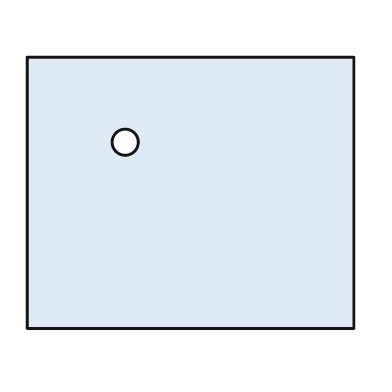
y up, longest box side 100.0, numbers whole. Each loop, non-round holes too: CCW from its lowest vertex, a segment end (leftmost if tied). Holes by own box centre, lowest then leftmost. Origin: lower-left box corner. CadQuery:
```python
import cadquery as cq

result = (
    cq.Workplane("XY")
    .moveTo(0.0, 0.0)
    .lineTo(100.0, 0.0)
    .lineTo(100.0, 83.0)
    .lineTo(0.0, 83.0)
    .close()
    .moveTo(30.0, 57.0)
    .circle(4.0)
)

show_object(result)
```